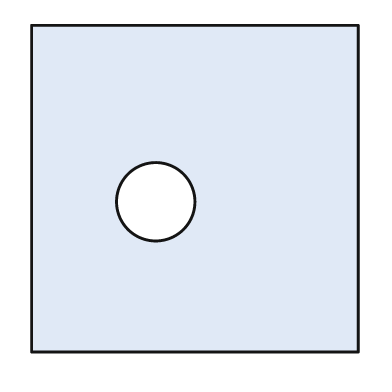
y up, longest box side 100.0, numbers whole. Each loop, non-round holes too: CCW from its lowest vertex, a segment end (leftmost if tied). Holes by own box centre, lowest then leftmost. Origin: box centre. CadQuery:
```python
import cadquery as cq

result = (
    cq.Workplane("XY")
    .moveTo(-50.0, -50.0)
    .lineTo(50.0, -50.0)
    .lineTo(50.0, 50.0)
    .lineTo(-50.0, 50.0)
    .close()
    .moveTo(-12.0, -4.0)
    .circle(12.0)
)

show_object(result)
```